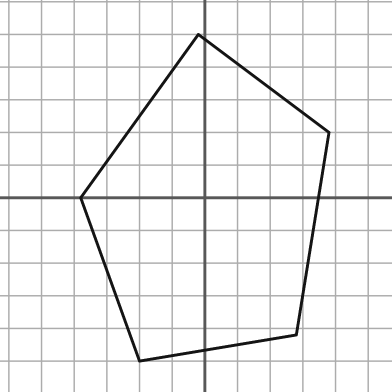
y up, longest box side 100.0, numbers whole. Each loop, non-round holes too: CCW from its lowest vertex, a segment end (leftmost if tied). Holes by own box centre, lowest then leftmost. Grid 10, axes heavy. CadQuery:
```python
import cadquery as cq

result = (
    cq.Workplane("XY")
    .moveTo(-20.0, -50.0)
    .lineTo(28.0, -42.0)
    .lineTo(38.0, 20.0)
    .lineTo(-2.0, 50.0)
    .lineTo(-38.0, 0.0)
    .close()
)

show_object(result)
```